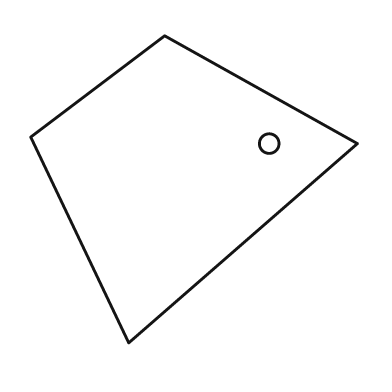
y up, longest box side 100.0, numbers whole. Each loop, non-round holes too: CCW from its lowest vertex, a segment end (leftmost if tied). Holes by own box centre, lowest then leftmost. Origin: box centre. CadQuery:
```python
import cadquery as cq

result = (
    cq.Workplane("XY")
    .moveTo(-20.0, -47.0)
    .lineTo(50.0, 14.0)
    .lineTo(-9.0, 47.0)
    .lineTo(-50.0, 16.0)
    .close()
    .moveTo(23.0, 14.0)
    .circle(3.0)
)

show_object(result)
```